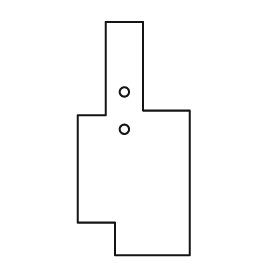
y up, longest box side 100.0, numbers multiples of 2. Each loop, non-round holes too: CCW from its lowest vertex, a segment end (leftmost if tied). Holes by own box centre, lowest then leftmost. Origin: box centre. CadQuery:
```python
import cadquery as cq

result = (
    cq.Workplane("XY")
    .moveTo(-8.0, -50.0)
    .lineTo(24.0, -50.0)
    .lineTo(24.0, 12.0)
    .lineTo(4.0, 12.0)
    .lineTo(4.0, 50.0)
    .lineTo(-12.0, 50.0)
    .lineTo(-12.0, 10.0)
    .lineTo(-24.0, 10.0)
    .lineTo(-24.0, -36.0)
    .lineTo(-8.0, -36.0)
    .close()
    .moveTo(-4.0, 4.0)
    .circle(2.0)
    .moveTo(-4.0, 20.0)
    .circle(2.0)
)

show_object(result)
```